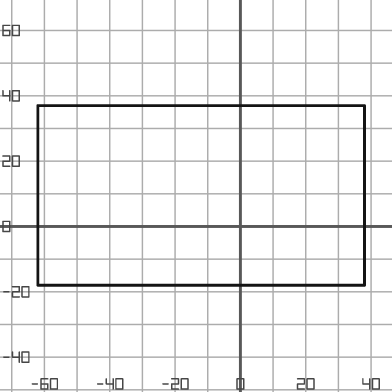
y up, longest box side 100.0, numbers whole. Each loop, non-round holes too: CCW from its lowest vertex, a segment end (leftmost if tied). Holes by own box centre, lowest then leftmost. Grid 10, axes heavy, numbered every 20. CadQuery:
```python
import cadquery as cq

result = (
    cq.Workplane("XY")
    .moveTo(-62.0, -18.0)
    .lineTo(38.0, -18.0)
    .lineTo(38.0, 37.0)
    .lineTo(-62.0, 37.0)
    .close()
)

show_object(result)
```